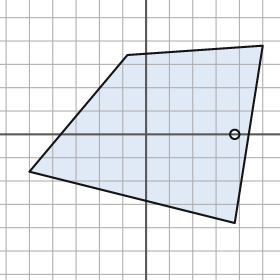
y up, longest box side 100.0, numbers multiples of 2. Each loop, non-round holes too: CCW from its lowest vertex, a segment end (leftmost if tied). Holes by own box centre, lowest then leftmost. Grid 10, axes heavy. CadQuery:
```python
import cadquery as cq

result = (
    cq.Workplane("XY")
    .moveTo(38.0, -38.0)
    .lineTo(50.0, 38.0)
    .lineTo(-8.0, 34.0)
    .lineTo(-50.0, -16.0)
    .close()
    .moveTo(38.0, 0.0)
    .circle(2.0)
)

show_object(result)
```